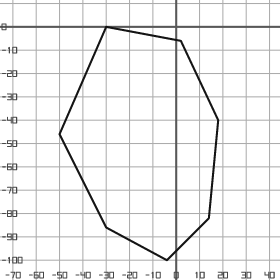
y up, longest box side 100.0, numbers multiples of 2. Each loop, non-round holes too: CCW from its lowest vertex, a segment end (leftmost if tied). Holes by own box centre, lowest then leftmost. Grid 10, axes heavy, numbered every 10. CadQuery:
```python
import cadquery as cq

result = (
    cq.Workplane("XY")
    .moveTo(-4.0, -100.0)
    .lineTo(14.0, -82.0)
    .lineTo(18.0, -40.0)
    .lineTo(2.0, -6.0)
    .lineTo(-30.0, 0.0)
    .lineTo(-50.0, -46.0)
    .lineTo(-30.0, -86.0)
    .close()
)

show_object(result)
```